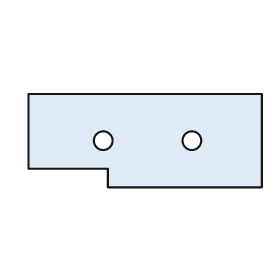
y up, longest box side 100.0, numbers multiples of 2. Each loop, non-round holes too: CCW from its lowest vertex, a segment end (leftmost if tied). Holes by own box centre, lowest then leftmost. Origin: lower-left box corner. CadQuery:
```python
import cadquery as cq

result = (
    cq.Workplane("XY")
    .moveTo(34.0, 0.0)
    .lineTo(100.0, 0.0)
    .lineTo(100.0, 40.0)
    .lineTo(0.0, 40.0)
    .lineTo(0.0, 8.0)
    .lineTo(34.0, 8.0)
    .close()
    .moveTo(32.0, 20.0)
    .circle(4.0)
    .moveTo(70.0, 20.0)
    .circle(4.0)
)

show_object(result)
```